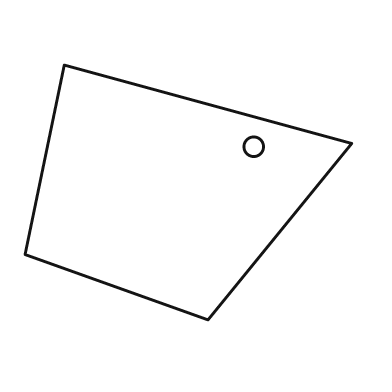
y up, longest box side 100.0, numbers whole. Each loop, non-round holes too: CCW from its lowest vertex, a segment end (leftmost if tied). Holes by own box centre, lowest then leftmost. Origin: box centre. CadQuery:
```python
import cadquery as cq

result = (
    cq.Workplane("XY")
    .moveTo(6.0, -39.0)
    .lineTo(50.0, 15.0)
    .lineTo(-38.0, 39.0)
    .lineTo(-50.0, -19.0)
    .close()
    .moveTo(20.0, 14.0)
    .circle(3.0)
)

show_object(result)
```